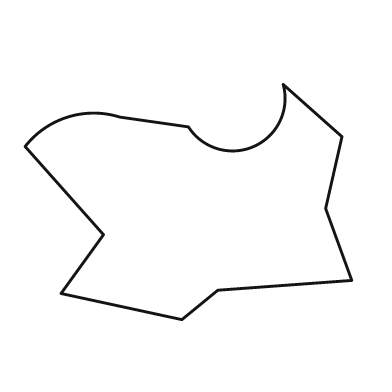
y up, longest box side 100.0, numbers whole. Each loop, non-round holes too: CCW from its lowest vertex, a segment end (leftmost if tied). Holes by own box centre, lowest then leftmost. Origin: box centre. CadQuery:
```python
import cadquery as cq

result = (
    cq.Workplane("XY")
    .moveTo(-2.0, -36.0)
    .lineTo(9.0, -27.0)
    .lineTo(50.0, -24.0)
    .lineTo(42.0, -2.0)
    .lineTo(47.0, 20.0)
    .lineTo(29.0, 36.0)
    .threePointArc((20.0, 17.0), (0.0, 23.0))
    .lineTo(-21.0, 26.0)
    .threePointArc((-37.0, 26.0), (-50.0, 17.0))
    .lineTo(-26.0, -10.0)
    .lineTo(-39.0, -28.0)
    .close()
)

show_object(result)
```